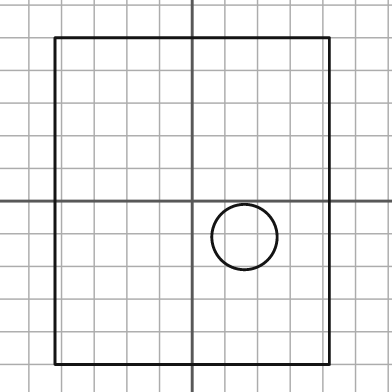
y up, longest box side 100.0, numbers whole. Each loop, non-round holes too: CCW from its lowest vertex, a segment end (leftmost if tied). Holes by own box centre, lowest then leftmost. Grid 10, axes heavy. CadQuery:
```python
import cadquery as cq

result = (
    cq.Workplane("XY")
    .moveTo(-42.0, -50.0)
    .lineTo(42.0, -50.0)
    .lineTo(42.0, 50.0)
    .lineTo(-42.0, 50.0)
    .close()
    .moveTo(16.0, -11.0)
    .circle(10.0)
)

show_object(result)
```